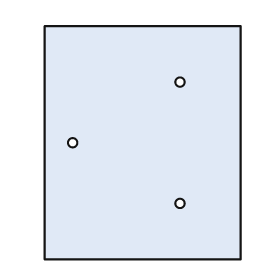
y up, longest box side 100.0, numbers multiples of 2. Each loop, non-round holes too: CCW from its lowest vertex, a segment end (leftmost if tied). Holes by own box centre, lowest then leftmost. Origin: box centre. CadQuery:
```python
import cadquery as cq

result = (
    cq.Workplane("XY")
    .moveTo(-42.0, -50.0)
    .lineTo(42.0, -50.0)
    .lineTo(42.0, 50.0)
    .lineTo(-42.0, 50.0)
    .close()
    .moveTo(16.0, -26.0)
    .circle(2.0)
    .moveTo(-30.0, 0.0)
    .circle(2.0)
    .moveTo(16.0, 26.0)
    .circle(2.0)
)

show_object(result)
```